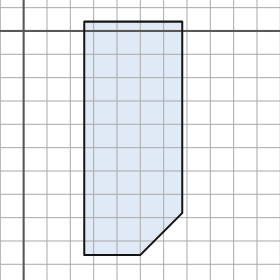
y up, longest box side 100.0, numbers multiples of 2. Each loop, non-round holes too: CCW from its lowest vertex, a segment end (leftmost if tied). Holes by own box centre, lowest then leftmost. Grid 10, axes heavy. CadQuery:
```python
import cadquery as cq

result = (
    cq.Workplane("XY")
    .moveTo(26.0, -96.0)
    .lineTo(50.0, -96.0)
    .lineTo(68.0, -78.0)
    .lineTo(68.0, 4.0)
    .lineTo(26.0, 4.0)
    .close()
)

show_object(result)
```